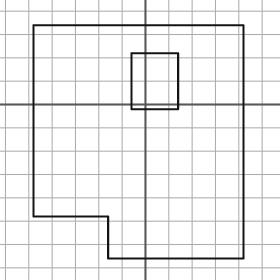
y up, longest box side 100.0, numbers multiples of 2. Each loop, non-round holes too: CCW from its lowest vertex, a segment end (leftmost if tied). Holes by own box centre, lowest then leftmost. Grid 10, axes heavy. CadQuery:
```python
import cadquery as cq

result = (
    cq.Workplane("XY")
    .moveTo(-16.0, -66.0)
    .lineTo(42.0, -66.0)
    .lineTo(42.0, 34.0)
    .lineTo(-48.0, 34.0)
    .lineTo(-48.0, -48.0)
    .lineTo(-16.0, -48.0)
    .close()
    .moveTo(-6.0, -2.0)
    .lineTo(14.0, -2.0)
    .lineTo(14.0, 22.0)
    .lineTo(-6.0, 22.0)
    .close()
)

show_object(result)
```